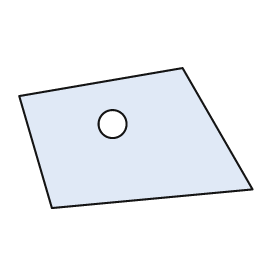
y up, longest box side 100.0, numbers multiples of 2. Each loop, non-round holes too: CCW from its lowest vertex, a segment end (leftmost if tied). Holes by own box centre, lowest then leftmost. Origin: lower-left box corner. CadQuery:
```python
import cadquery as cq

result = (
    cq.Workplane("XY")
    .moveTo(14.0, 0.0)
    .lineTo(100.0, 8.0)
    .lineTo(70.0, 60.0)
    .lineTo(0.0, 48.0)
    .close()
    .moveTo(40.0, 36.0)
    .circle(6.0)
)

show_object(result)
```